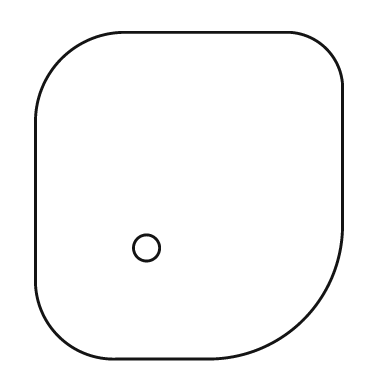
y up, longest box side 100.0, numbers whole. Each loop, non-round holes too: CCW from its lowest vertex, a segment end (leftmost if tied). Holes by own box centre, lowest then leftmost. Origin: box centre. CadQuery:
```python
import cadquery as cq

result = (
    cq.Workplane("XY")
    .moveTo(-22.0, -50.0)
    .lineTo(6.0, -50.0)
    .threePointArc((35.0, -38.0), (47.0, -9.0))
    .lineTo(47.0, 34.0)
    .threePointArc((42.0, 45.0), (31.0, 50.0))
    .lineTo(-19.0, 50.0)
    .threePointArc((-39.0, 42.0), (-47.0, 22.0))
    .lineTo(-47.0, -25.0)
    .threePointArc((-40.0, -43.0), (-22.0, -50.0))
    .close()
    .moveTo(-13.0, -16.0)
    .circle(4.0)
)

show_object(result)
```